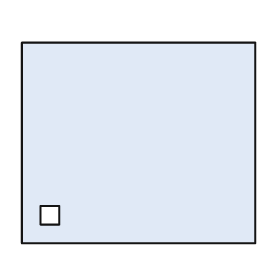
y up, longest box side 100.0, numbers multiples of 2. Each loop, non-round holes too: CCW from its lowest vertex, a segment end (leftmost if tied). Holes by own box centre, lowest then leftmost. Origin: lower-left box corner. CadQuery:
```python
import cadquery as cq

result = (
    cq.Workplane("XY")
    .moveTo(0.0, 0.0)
    .lineTo(100.0, 0.0)
    .lineTo(100.0, 86.0)
    .lineTo(0.0, 86.0)
    .close()
    .moveTo(8.0, 8.0)
    .lineTo(16.0, 8.0)
    .lineTo(16.0, 16.0)
    .lineTo(8.0, 16.0)
    .close()
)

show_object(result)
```